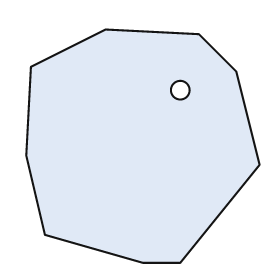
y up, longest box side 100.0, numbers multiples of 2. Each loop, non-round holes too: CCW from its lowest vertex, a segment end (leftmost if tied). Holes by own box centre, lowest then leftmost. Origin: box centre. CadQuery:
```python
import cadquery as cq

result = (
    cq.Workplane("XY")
    .moveTo(0.0, -50.0)
    .lineTo(16.0, -50.0)
    .lineTo(50.0, -8.0)
    .lineTo(40.0, 32.0)
    .lineTo(24.0, 48.0)
    .lineTo(-16.0, 50.0)
    .lineTo(-48.0, 34.0)
    .lineTo(-50.0, -4.0)
    .lineTo(-42.0, -38.0)
    .close()
    .moveTo(16.0, 24.0)
    .circle(4.0)
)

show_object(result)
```